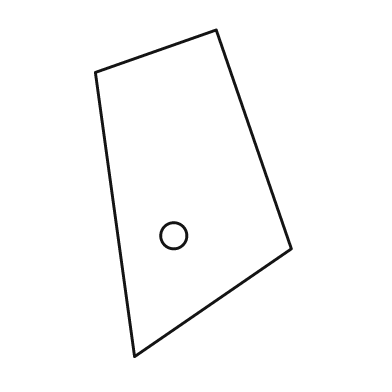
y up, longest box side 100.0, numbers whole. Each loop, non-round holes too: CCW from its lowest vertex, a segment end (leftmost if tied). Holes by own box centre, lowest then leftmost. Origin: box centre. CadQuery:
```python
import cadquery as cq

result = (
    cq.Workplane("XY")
    .moveTo(-18.0, -50.0)
    .lineTo(30.0, -17.0)
    .lineTo(7.0, 50.0)
    .lineTo(-30.0, 37.0)
    .close()
    .moveTo(-6.0, -13.0)
    .circle(4.0)
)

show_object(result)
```